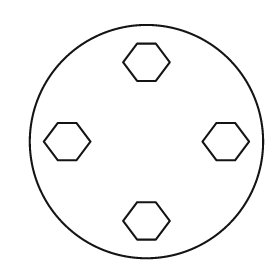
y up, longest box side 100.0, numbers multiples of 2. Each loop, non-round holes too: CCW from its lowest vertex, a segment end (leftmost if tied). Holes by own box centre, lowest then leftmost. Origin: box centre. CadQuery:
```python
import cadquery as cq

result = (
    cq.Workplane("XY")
    .moveTo(0.0, 0.0)
    .circle(50.0)
    .moveTo(-4.0, -42.0)
    .lineTo(4.0, -42.0)
    .lineTo(10.0, -34.0)
    .lineTo(4.0, -26.0)
    .lineTo(-4.0, -26.0)
    .lineTo(-10.0, -34.0)
    .close()
    .moveTo(-38.0, -8.0)
    .lineTo(-30.0, -8.0)
    .lineTo(-24.0, 0.0)
    .lineTo(-30.0, 8.0)
    .lineTo(-38.0, 8.0)
    .lineTo(-44.0, 0.0)
    .close()
    .moveTo(30.0, -8.0)
    .lineTo(38.0, -8.0)
    .lineTo(44.0, 0.0)
    .lineTo(38.0, 8.0)
    .lineTo(30.0, 8.0)
    .lineTo(24.0, 0.0)
    .close()
    .moveTo(-4.0, 26.0)
    .lineTo(4.0, 26.0)
    .lineTo(10.0, 34.0)
    .lineTo(4.0, 42.0)
    .lineTo(-4.0, 42.0)
    .lineTo(-10.0, 34.0)
    .close()
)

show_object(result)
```